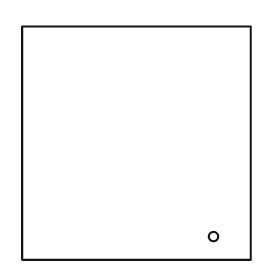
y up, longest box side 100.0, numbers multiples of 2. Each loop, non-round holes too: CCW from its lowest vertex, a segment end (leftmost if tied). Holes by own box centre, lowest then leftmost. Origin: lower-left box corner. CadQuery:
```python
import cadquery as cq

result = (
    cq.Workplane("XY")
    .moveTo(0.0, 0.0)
    .lineTo(98.0, 0.0)
    .lineTo(98.0, 100.0)
    .lineTo(0.0, 100.0)
    .close()
    .moveTo(82.0, 10.0)
    .circle(2.0)
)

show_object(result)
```